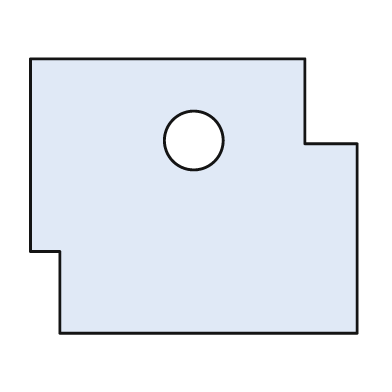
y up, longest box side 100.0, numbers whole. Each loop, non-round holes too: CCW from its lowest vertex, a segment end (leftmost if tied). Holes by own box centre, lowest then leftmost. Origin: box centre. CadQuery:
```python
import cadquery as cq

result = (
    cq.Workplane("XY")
    .moveTo(-41.0, -42.0)
    .lineTo(50.0, -42.0)
    .lineTo(50.0, 16.0)
    .lineTo(34.0, 16.0)
    .lineTo(34.0, 42.0)
    .lineTo(-50.0, 42.0)
    .lineTo(-50.0, -17.0)
    .lineTo(-41.0, -17.0)
    .close()
    .moveTo(0.0, 17.0)
    .circle(9.0)
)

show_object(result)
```